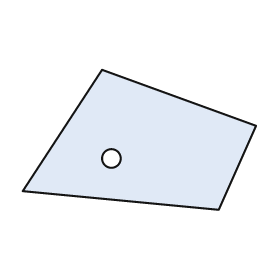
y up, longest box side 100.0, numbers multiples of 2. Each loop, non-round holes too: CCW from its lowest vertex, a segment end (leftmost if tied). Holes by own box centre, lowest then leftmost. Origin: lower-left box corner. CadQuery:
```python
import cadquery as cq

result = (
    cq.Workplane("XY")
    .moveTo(84.0, 0.0)
    .lineTo(100.0, 36.0)
    .lineTo(34.0, 60.0)
    .lineTo(0.0, 8.0)
    .close()
    .moveTo(38.0, 22.0)
    .circle(4.0)
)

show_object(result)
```